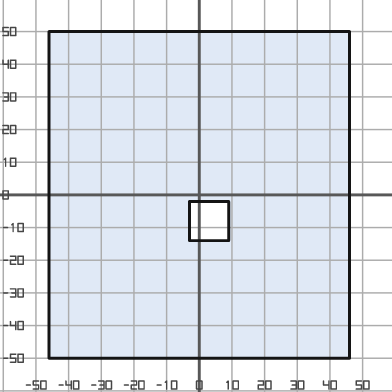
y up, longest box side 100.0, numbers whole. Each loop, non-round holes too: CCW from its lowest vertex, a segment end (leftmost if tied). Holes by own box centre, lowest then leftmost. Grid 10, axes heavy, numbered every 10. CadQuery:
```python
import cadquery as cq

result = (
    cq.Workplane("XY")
    .moveTo(-46.0, -50.0)
    .lineTo(46.0, -50.0)
    .lineTo(46.0, 50.0)
    .lineTo(-46.0, 50.0)
    .close()
    .moveTo(-3.0, -14.0)
    .lineTo(9.0, -14.0)
    .lineTo(9.0, -2.0)
    .lineTo(-3.0, -2.0)
    .close()
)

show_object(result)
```